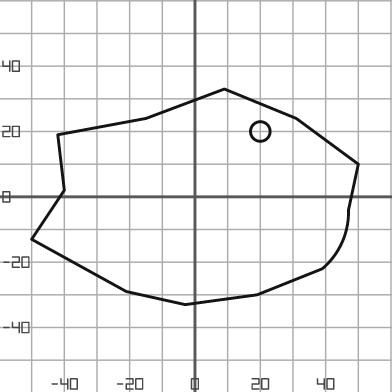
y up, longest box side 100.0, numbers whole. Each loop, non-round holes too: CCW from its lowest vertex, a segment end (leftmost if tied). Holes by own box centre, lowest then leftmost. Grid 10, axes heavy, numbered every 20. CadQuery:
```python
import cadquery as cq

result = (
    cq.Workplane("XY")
    .moveTo(-3.0, -33.0)
    .lineTo(19.0, -30.0)
    .lineTo(39.0, -22.0)
    .threePointArc((45.0, -14.0), (47.0, -4.0))
    .lineTo(50.0, 10.0)
    .lineTo(31.0, 24.0)
    .lineTo(9.0, 33.0)
    .lineTo(-15.0, 24.0)
    .lineTo(-42.0, 19.0)
    .lineTo(-40.0, 2.0)
    .lineTo(-50.0, -13.0)
    .lineTo(-21.0, -29.0)
    .close()
    .moveTo(20.0, 20.0)
    .circle(3.0)
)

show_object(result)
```